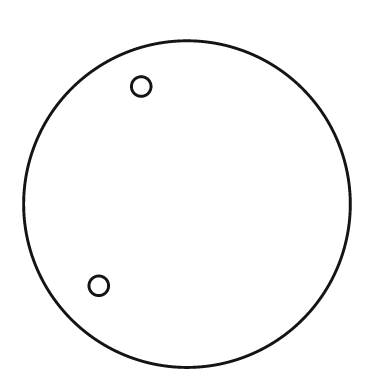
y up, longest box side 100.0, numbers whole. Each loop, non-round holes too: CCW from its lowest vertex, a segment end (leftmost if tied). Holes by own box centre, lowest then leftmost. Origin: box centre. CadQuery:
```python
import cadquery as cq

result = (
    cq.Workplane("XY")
    .moveTo(0.0, 0.0)
    .circle(50.0)
    .moveTo(-27.0, -25.0)
    .circle(3.0)
    .moveTo(-14.0, 36.0)
    .circle(3.0)
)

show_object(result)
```